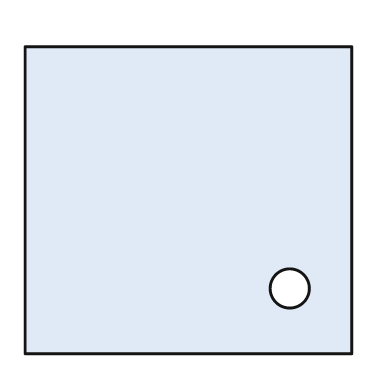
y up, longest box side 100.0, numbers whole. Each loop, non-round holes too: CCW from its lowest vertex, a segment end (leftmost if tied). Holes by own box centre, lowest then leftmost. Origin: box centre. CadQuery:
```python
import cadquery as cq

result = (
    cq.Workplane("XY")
    .moveTo(-50.0, -47.0)
    .lineTo(50.0, -47.0)
    .lineTo(50.0, 47.0)
    .lineTo(-50.0, 47.0)
    .close()
    .moveTo(31.0, -27.0)
    .circle(6.0)
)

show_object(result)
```